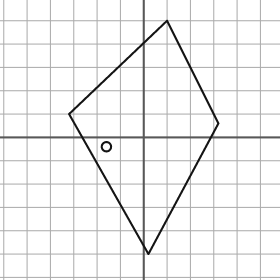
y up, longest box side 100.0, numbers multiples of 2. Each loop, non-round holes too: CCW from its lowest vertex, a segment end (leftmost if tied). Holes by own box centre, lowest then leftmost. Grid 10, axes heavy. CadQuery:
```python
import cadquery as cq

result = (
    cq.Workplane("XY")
    .moveTo(2.0, -50.0)
    .lineTo(32.0, 6.0)
    .lineTo(10.0, 50.0)
    .lineTo(-32.0, 10.0)
    .close()
    .moveTo(-16.0, -4.0)
    .circle(2.0)
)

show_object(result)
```